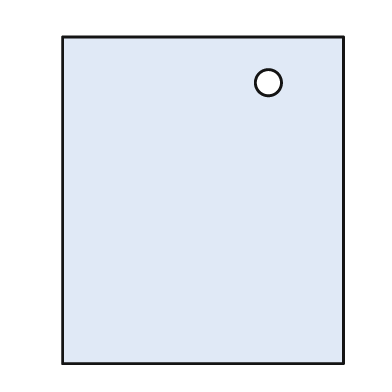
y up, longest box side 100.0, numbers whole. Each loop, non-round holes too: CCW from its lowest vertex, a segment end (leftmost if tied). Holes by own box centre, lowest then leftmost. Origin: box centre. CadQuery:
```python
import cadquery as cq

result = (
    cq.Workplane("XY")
    .moveTo(-43.0, -50.0)
    .lineTo(43.0, -50.0)
    .lineTo(43.0, 50.0)
    .lineTo(-43.0, 50.0)
    .close()
    .moveTo(20.0, 36.0)
    .circle(4.0)
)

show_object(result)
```